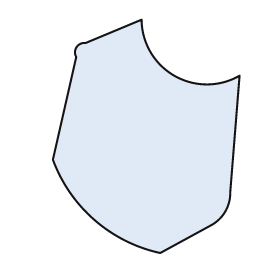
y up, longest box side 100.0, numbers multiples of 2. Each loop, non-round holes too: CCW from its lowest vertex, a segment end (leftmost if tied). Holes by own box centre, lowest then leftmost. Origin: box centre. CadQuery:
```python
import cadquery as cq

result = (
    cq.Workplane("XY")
    .moveTo(6.0, -50.0)
    .lineTo(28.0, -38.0)
    .threePointArc((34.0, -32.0), (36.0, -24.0))
    .lineTo(40.0, 26.0)
    .threePointArc((12.0, 26.0), (-2.0, 50.0))
    .lineTo(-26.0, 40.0)
    .threePointArc((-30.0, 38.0), (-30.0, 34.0))
    .lineTo(-40.0, -10.0)
    .threePointArc((-22.0, -36.0), (6.0, -50.0))
    .close()
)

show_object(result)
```